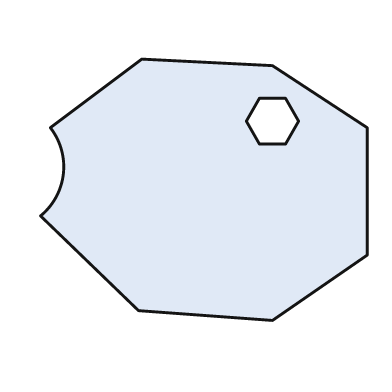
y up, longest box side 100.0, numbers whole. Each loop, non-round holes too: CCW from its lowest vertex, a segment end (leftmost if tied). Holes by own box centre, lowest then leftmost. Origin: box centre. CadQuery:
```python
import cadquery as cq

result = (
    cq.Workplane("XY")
    .moveTo(21.0, -40.0)
    .lineTo(50.0, -20.0)
    .lineTo(50.0, 19.0)
    .lineTo(21.0, 38.0)
    .lineTo(-19.0, 40.0)
    .lineTo(-47.0, 19.0)
    .threePointArc((-43.0, 5.0), (-50.0, -8.0))
    .lineTo(-20.0, -37.0)
    .close()
    .moveTo(17.0, 14.0)
    .lineTo(25.0, 14.0)
    .lineTo(29.0, 21.0)
    .lineTo(25.0, 28.0)
    .lineTo(17.0, 28.0)
    .lineTo(13.0, 21.0)
    .close()
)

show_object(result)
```